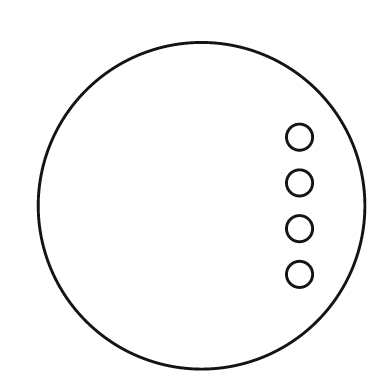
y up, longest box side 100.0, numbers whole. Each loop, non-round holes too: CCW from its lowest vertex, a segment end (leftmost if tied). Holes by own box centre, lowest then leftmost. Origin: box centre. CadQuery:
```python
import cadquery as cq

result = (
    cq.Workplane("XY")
    .moveTo(0.0, 0.0)
    .circle(50.0)
    .moveTo(30.0, -21.0)
    .circle(4.0)
    .moveTo(30.0, -7.0)
    .circle(4.0)
    .moveTo(30.0, 7.0)
    .circle(4.0)
    .moveTo(30.0, 21.0)
    .circle(4.0)
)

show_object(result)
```